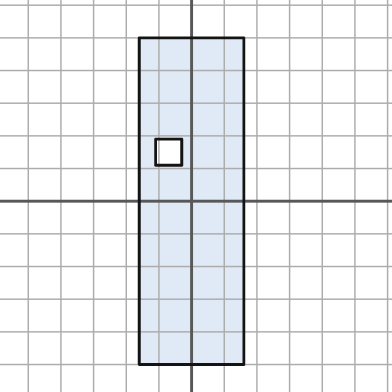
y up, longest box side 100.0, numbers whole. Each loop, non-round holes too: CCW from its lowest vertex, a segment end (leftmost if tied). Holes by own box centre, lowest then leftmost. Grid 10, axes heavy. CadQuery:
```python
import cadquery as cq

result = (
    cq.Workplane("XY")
    .moveTo(-16.0, -50.0)
    .lineTo(16.0, -50.0)
    .lineTo(16.0, 50.0)
    .lineTo(-16.0, 50.0)
    .close()
    .moveTo(-11.0, 11.0)
    .lineTo(-3.0, 11.0)
    .lineTo(-3.0, 19.0)
    .lineTo(-11.0, 19.0)
    .close()
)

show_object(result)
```